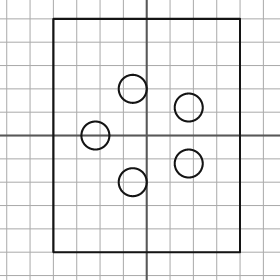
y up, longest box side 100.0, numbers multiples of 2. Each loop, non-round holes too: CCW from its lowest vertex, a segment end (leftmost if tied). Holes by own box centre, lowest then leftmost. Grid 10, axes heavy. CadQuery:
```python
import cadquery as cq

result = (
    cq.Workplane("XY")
    .moveTo(-40.0, -50.0)
    .lineTo(40.0, -50.0)
    .lineTo(40.0, 50.0)
    .lineTo(-40.0, 50.0)
    .close()
    .moveTo(-6.0, -20.0)
    .circle(6.0)
    .moveTo(18.0, -12.0)
    .circle(6.0)
    .moveTo(-22.0, 0.0)
    .circle(6.0)
    .moveTo(18.0, 12.0)
    .circle(6.0)
    .moveTo(-6.0, 20.0)
    .circle(6.0)
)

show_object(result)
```